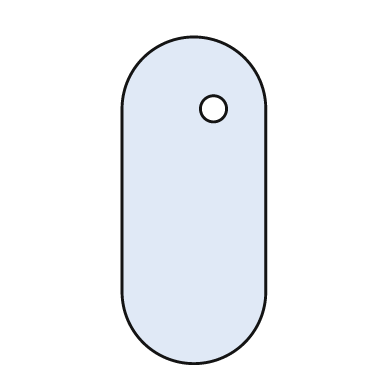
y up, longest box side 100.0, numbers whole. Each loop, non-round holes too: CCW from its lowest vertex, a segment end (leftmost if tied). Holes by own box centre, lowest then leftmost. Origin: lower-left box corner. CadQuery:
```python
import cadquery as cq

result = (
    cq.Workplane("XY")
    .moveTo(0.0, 22.0)
    .threePointArc((22.0, 0.0), (44.0, 22.0))
    .lineTo(44.0, 78.0)
    .threePointArc((22.0, 100.0), (0.0, 78.0))
    .close()
    .moveTo(28.0, 78.0)
    .circle(4.0)
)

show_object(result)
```